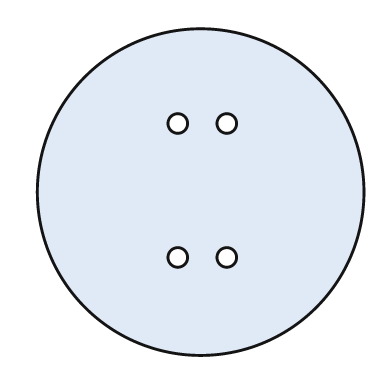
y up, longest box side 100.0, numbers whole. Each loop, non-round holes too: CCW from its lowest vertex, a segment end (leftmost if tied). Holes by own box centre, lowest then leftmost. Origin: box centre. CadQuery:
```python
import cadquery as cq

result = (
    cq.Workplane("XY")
    .moveTo(0.0, 0.0)
    .circle(50.0)
    .moveTo(-7.0, -20.0)
    .circle(3.0)
    .moveTo(8.0, -20.0)
    .circle(3.0)
    .moveTo(-7.0, 21.0)
    .circle(3.0)
    .moveTo(8.0, 21.0)
    .circle(3.0)
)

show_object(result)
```